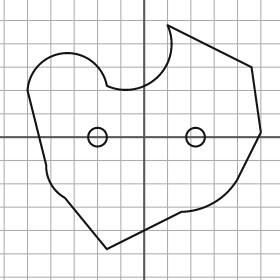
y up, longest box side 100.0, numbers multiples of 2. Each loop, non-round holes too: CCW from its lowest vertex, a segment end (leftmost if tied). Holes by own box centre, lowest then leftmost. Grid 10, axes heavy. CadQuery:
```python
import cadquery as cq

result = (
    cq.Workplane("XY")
    .moveTo(-16.0, -48.0)
    .lineTo(16.0, -32.0)
    .threePointArc((30.0, -28.0), (40.0, -18.0))
    .lineTo(50.0, 2.0)
    .lineTo(46.0, 30.0)
    .lineTo(10.0, 48.0)
    .threePointArc((6.0, 26.0), (-16.0, 22.0))
    .threePointArc((-34.0, 36.0), (-50.0, 20.0))
    .lineTo(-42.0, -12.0)
    .threePointArc((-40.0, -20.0), (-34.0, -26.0))
    .close()
    .moveTo(-20.0, 0.0)
    .circle(4.0)
    .moveTo(22.0, 0.0)
    .circle(4.0)
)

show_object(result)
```